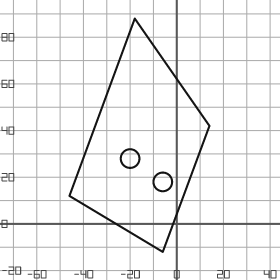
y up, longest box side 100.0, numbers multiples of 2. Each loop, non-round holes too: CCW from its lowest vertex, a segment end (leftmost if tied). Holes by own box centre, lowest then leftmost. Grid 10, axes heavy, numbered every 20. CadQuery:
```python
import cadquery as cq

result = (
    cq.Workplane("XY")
    .moveTo(-6.0, -12.0)
    .lineTo(14.0, 42.0)
    .lineTo(-18.0, 88.0)
    .lineTo(-46.0, 12.0)
    .close()
    .moveTo(-6.0, 18.0)
    .circle(4.0)
    .moveTo(-20.0, 28.0)
    .circle(4.0)
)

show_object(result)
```